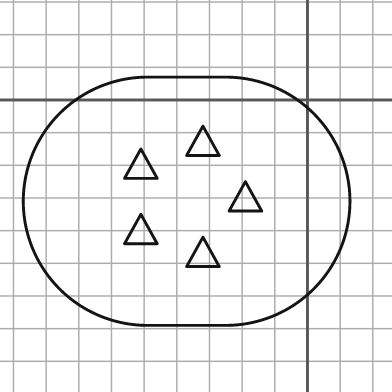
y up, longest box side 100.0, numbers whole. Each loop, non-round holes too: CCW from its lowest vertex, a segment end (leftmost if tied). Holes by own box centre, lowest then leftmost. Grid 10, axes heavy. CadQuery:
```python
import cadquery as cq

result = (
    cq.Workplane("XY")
    .moveTo(-49.0, -69.0)
    .lineTo(-25.0, -69.0)
    .threePointArc((13.0, -31.0), (-25.0, 7.0))
    .lineTo(-49.0, 7.0)
    .threePointArc((-87.0, -31.0), (-49.0, -69.0))
    .close()
    .moveTo(-37.0, -51.0)
    .lineTo(-27.0, -51.0)
    .lineTo(-32.0, -42.0)
    .close()
    .moveTo(-56.0, -44.0)
    .lineTo(-46.0, -44.0)
    .lineTo(-51.0, -35.0)
    .close()
    .moveTo(-24.0, -34.0)
    .lineTo(-14.0, -34.0)
    .lineTo(-19.0, -25.0)
    .close()
    .moveTo(-56.0, -24.0)
    .lineTo(-46.0, -24.0)
    .lineTo(-51.0, -15.0)
    .close()
    .moveTo(-37.0, -17.0)
    .lineTo(-27.0, -17.0)
    .lineTo(-32.0, -8.0)
    .close()
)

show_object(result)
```